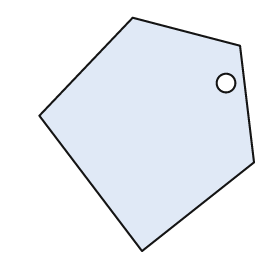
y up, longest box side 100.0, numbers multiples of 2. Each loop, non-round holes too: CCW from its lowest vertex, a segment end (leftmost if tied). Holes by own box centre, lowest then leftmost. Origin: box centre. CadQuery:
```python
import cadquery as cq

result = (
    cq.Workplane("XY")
    .moveTo(-2.0, -50.0)
    .lineTo(46.0, -12.0)
    .lineTo(40.0, 38.0)
    .lineTo(-6.0, 50.0)
    .lineTo(-46.0, 8.0)
    .close()
    .moveTo(34.0, 22.0)
    .circle(4.0)
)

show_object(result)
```